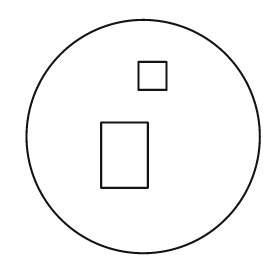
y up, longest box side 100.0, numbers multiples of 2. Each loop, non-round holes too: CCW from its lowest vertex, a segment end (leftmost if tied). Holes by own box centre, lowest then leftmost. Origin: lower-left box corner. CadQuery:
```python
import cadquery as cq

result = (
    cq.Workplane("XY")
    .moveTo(50.0, 50.0)
    .circle(50.0)
    .moveTo(32.0, 28.0)
    .lineTo(52.0, 28.0)
    .lineTo(52.0, 56.0)
    .lineTo(32.0, 56.0)
    .close()
    .moveTo(48.0, 70.0)
    .lineTo(60.0, 70.0)
    .lineTo(60.0, 82.0)
    .lineTo(48.0, 82.0)
    .close()
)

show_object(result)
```